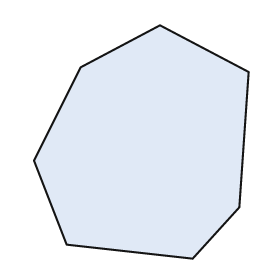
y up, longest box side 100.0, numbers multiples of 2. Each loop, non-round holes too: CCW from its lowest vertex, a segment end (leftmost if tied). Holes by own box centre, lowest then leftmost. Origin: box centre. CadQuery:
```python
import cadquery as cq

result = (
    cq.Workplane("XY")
    .moveTo(22.0, -50.0)
    .lineTo(42.0, -28.0)
    .lineTo(46.0, 30.0)
    .lineTo(8.0, 50.0)
    .lineTo(-26.0, 32.0)
    .lineTo(-46.0, -8.0)
    .lineTo(-32.0, -44.0)
    .close()
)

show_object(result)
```